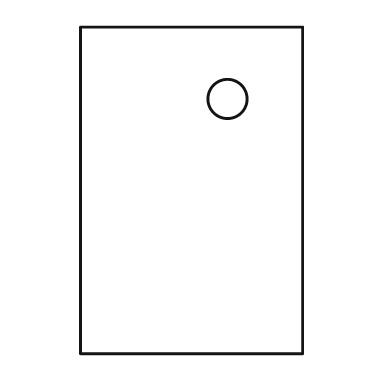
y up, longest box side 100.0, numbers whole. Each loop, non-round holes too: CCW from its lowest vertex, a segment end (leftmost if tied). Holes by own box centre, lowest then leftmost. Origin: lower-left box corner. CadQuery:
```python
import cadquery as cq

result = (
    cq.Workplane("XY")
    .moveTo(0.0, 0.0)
    .lineTo(68.0, 0.0)
    .lineTo(68.0, 100.0)
    .lineTo(0.0, 100.0)
    .close()
    .moveTo(45.0, 78.0)
    .circle(6.0)
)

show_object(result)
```